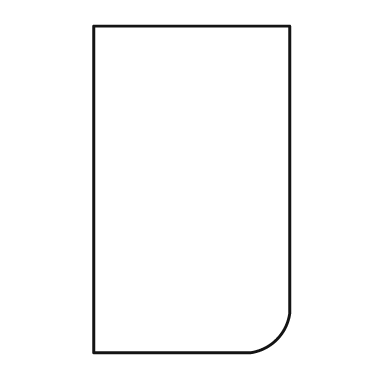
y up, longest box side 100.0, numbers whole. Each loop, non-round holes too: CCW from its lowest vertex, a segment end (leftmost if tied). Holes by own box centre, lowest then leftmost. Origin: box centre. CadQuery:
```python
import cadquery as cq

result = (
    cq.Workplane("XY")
    .moveTo(-30.0, -50.0)
    .lineTo(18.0, -50.0)
    .threePointArc((26.0, -46.0), (30.0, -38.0))
    .lineTo(30.0, 50.0)
    .lineTo(-30.0, 50.0)
    .close()
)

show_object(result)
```